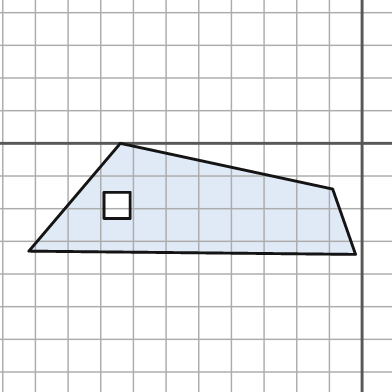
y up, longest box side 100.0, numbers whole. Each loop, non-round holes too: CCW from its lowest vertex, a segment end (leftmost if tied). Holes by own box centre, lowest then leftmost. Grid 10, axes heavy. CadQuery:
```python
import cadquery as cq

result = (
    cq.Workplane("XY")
    .moveTo(-2.0, -34.0)
    .lineTo(-9.0, -14.0)
    .lineTo(-74.0, 0.0)
    .lineTo(-102.0, -33.0)
    .close()
    .moveTo(-79.0, -23.0)
    .lineTo(-71.0, -23.0)
    .lineTo(-71.0, -15.0)
    .lineTo(-79.0, -15.0)
    .close()
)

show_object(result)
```